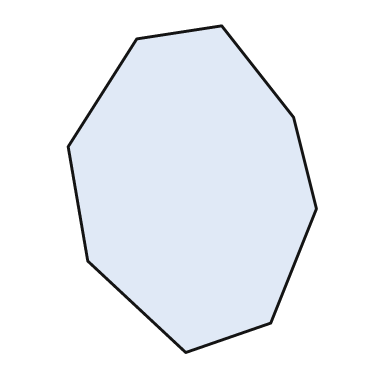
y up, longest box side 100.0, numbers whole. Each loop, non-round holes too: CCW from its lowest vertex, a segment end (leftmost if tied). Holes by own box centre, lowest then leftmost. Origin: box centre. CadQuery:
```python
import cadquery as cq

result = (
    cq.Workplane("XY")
    .moveTo(-2.0, -50.0)
    .lineTo(24.0, -41.0)
    .lineTo(38.0, -6.0)
    .lineTo(31.0, 22.0)
    .lineTo(9.0, 50.0)
    .lineTo(-17.0, 46.0)
    .lineTo(-38.0, 13.0)
    .lineTo(-32.0, -22.0)
    .close()
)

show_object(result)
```